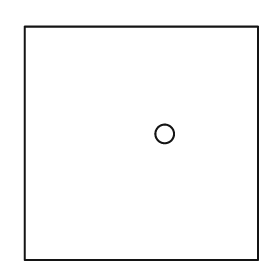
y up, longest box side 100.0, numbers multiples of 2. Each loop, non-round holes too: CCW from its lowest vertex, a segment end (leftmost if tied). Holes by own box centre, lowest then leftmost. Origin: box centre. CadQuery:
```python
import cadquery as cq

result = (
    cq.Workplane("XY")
    .moveTo(-50.0, -50.0)
    .lineTo(50.0, -50.0)
    .lineTo(50.0, 50.0)
    .lineTo(-50.0, 50.0)
    .close()
    .moveTo(10.0, 4.0)
    .circle(4.0)
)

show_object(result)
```